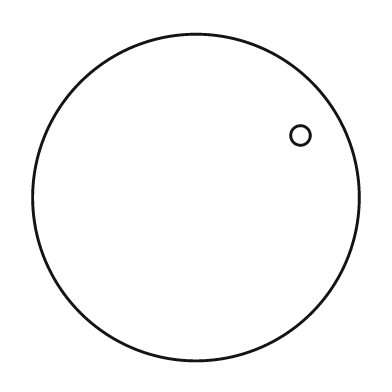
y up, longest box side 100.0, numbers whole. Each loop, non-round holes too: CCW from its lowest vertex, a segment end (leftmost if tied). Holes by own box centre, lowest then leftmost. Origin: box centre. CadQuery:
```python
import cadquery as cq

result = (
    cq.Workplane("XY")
    .moveTo(0.0, 0.0)
    .circle(50.0)
    .moveTo(32.0, 19.0)
    .circle(3.0)
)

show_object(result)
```